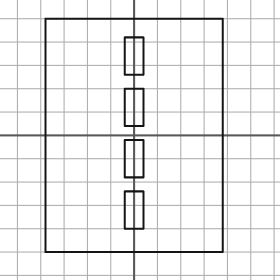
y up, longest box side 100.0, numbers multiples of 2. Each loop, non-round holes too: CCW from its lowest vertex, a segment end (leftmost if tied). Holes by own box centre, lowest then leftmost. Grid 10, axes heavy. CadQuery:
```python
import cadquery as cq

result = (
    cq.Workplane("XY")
    .moveTo(-38.0, -50.0)
    .lineTo(38.0, -50.0)
    .lineTo(38.0, 50.0)
    .lineTo(-38.0, 50.0)
    .close()
    .moveTo(-4.0, -40.0)
    .lineTo(4.0, -40.0)
    .lineTo(4.0, -24.0)
    .lineTo(-4.0, -24.0)
    .close()
    .moveTo(-4.0, -18.0)
    .lineTo(4.0, -18.0)
    .lineTo(4.0, -2.0)
    .lineTo(-4.0, -2.0)
    .close()
    .moveTo(-4.0, 4.0)
    .lineTo(4.0, 4.0)
    .lineTo(4.0, 20.0)
    .lineTo(-4.0, 20.0)
    .close()
    .moveTo(-4.0, 26.0)
    .lineTo(4.0, 26.0)
    .lineTo(4.0, 42.0)
    .lineTo(-4.0, 42.0)
    .close()
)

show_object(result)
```